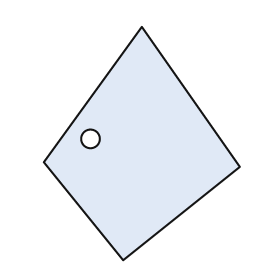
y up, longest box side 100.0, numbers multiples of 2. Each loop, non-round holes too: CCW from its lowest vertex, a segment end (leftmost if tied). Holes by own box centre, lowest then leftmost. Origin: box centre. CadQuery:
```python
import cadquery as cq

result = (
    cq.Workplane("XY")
    .moveTo(-8.0, -50.0)
    .lineTo(42.0, -10.0)
    .lineTo(0.0, 50.0)
    .lineTo(-42.0, -8.0)
    .close()
    .moveTo(-22.0, 2.0)
    .circle(4.0)
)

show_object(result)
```